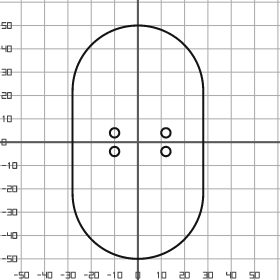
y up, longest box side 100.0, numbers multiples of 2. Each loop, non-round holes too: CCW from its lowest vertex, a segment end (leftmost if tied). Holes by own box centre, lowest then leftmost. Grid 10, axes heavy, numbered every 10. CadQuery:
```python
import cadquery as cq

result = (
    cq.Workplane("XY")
    .moveTo(-28.0, -22.0)
    .threePointArc((0.0, -50.0), (28.0, -22.0))
    .lineTo(28.0, 22.0)
    .threePointArc((0.0, 50.0), (-28.0, 22.0))
    .close()
    .moveTo(-10.0, -4.0)
    .circle(2.0)
    .moveTo(12.0, -4.0)
    .circle(2.0)
    .moveTo(-10.0, 4.0)
    .circle(2.0)
    .moveTo(12.0, 4.0)
    .circle(2.0)
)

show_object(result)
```